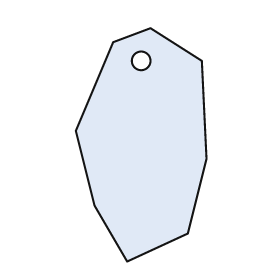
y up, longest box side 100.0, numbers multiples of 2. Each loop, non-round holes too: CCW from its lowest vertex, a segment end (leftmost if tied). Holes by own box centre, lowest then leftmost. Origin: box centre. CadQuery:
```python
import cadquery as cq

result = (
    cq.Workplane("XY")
    .moveTo(-6.0, -50.0)
    .lineTo(20.0, -38.0)
    .lineTo(28.0, -6.0)
    .lineTo(26.0, 36.0)
    .lineTo(4.0, 50.0)
    .lineTo(-12.0, 44.0)
    .lineTo(-28.0, 6.0)
    .lineTo(-20.0, -26.0)
    .close()
    .moveTo(0.0, 36.0)
    .circle(4.0)
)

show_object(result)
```